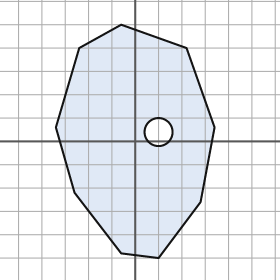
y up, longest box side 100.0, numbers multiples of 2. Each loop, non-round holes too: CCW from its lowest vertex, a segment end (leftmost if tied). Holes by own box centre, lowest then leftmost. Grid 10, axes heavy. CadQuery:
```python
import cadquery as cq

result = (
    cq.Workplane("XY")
    .moveTo(10.0, -50.0)
    .lineTo(28.0, -26.0)
    .lineTo(34.0, 6.0)
    .lineTo(22.0, 40.0)
    .lineTo(-6.0, 50.0)
    .lineTo(-24.0, 40.0)
    .lineTo(-34.0, 6.0)
    .lineTo(-26.0, -22.0)
    .lineTo(-6.0, -48.0)
    .close()
    .moveTo(10.0, 4.0)
    .circle(6.0)
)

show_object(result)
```